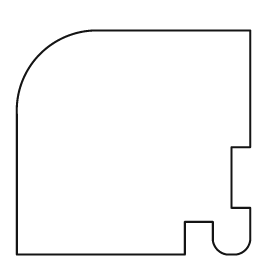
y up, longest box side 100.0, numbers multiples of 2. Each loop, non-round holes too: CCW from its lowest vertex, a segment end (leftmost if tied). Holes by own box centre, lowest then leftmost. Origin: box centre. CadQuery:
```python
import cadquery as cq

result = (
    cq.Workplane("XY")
    .moveTo(-50.0, -48.0)
    .lineTo(22.0, -48.0)
    .lineTo(22.0, -34.0)
    .lineTo(34.0, -34.0)
    .lineTo(34.0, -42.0)
    .threePointArc((36.0, -46.0), (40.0, -48.0))
    .lineTo(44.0, -48.0)
    .threePointArc((48.0, -46.0), (50.0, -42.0))
    .lineTo(50.0, -28.0)
    .lineTo(42.0, -28.0)
    .lineTo(42.0, -2.0)
    .lineTo(50.0, -2.0)
    .lineTo(50.0, 48.0)
    .lineTo(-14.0, 48.0)
    .threePointArc((-40.0, 38.0), (-50.0, 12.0))
    .close()
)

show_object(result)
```